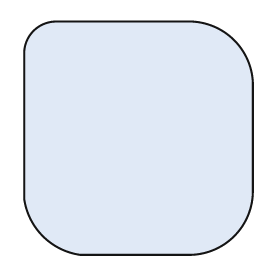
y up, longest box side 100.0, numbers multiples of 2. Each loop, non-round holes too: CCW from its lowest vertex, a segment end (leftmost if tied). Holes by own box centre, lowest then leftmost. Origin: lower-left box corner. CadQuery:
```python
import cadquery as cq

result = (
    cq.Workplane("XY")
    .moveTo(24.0, 0.0)
    .lineTo(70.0, 0.0)
    .threePointArc((90.0, 8.0), (98.0, 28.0))
    .lineTo(98.0, 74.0)
    .threePointArc((90.0, 92.0), (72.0, 100.0))
    .lineTo(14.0, 100.0)
    .threePointArc((4.0, 96.0), (0.0, 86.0))
    .lineTo(0.0, 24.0)
    .threePointArc((8.0, 8.0), (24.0, 0.0))
    .close()
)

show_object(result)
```